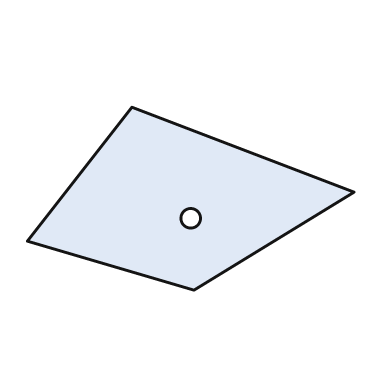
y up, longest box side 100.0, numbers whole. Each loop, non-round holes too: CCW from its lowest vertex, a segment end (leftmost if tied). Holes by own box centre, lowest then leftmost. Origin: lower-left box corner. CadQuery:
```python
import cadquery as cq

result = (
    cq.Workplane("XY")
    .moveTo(51.0, 0.0)
    .lineTo(100.0, 30.0)
    .lineTo(32.0, 56.0)
    .lineTo(0.0, 15.0)
    .close()
    .moveTo(50.0, 22.0)
    .circle(3.0)
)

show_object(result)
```